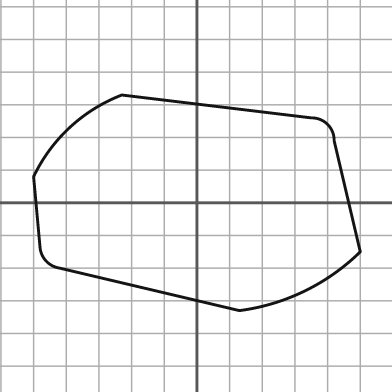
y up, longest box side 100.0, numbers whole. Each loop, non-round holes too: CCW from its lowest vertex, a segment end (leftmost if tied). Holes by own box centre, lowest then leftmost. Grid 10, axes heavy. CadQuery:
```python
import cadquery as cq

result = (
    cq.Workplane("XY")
    .moveTo(13.0, -33.0)
    .threePointArc((33.0, -27.0), (50.0, -15.0))
    .lineTo(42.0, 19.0)
    .threePointArc((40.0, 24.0), (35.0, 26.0))
    .lineTo(-23.0, 33.0)
    .threePointArc((-39.0, 23.0), (-50.0, 8.0))
    .lineTo(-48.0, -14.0)
    .threePointArc((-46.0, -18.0), (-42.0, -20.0))
    .close()
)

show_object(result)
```